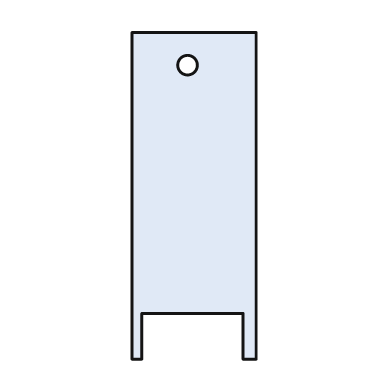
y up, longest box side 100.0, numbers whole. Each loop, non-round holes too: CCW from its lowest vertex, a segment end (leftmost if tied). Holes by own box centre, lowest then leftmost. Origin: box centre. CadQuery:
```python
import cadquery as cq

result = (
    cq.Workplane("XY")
    .moveTo(-19.0, -50.0)
    .lineTo(-16.0, -50.0)
    .lineTo(-16.0, -36.0)
    .lineTo(15.0, -36.0)
    .lineTo(15.0, -50.0)
    .lineTo(19.0, -50.0)
    .lineTo(19.0, 50.0)
    .lineTo(-19.0, 50.0)
    .close()
    .moveTo(-2.0, 40.0)
    .circle(3.0)
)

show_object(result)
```